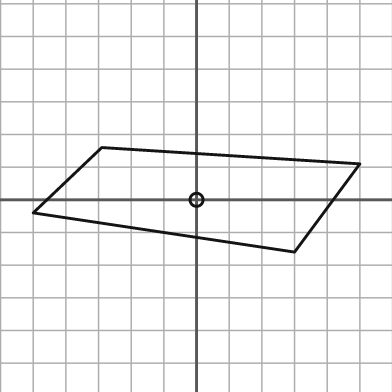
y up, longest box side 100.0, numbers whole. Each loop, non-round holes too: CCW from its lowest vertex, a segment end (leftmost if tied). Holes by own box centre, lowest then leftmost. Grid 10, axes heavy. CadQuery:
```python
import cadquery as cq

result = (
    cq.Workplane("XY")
    .moveTo(30.0, -16.0)
    .lineTo(50.0, 11.0)
    .lineTo(-29.0, 16.0)
    .lineTo(-50.0, -4.0)
    .close()
    .moveTo(0.0, 0.0)
    .circle(2.0)
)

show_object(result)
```